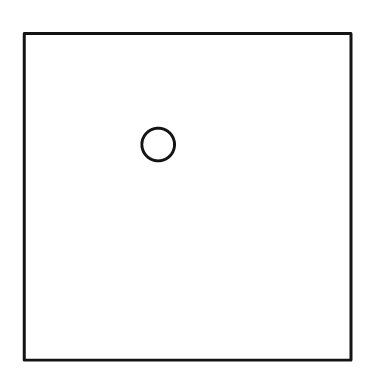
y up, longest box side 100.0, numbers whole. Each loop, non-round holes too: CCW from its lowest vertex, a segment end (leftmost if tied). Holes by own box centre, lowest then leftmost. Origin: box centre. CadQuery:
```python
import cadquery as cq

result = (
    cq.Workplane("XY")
    .moveTo(-50.0, -50.0)
    .lineTo(50.0, -50.0)
    .lineTo(50.0, 50.0)
    .lineTo(-50.0, 50.0)
    .close()
    .moveTo(-9.0, 16.0)
    .circle(5.0)
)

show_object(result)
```